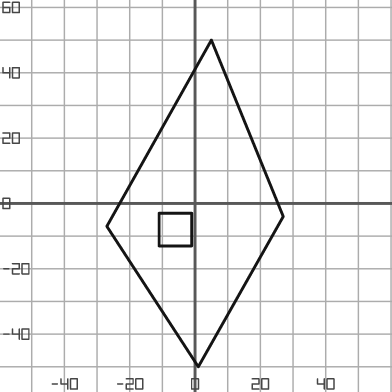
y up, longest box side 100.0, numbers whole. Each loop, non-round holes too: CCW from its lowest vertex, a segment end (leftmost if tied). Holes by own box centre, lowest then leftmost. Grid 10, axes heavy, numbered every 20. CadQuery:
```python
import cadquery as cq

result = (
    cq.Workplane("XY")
    .moveTo(1.0, -50.0)
    .lineTo(27.0, -4.0)
    .lineTo(5.0, 50.0)
    .lineTo(-27.0, -7.0)
    .close()
    .moveTo(-11.0, -13.0)
    .lineTo(-1.0, -13.0)
    .lineTo(-1.0, -3.0)
    .lineTo(-11.0, -3.0)
    .close()
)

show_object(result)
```